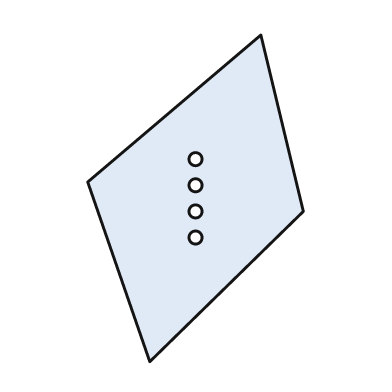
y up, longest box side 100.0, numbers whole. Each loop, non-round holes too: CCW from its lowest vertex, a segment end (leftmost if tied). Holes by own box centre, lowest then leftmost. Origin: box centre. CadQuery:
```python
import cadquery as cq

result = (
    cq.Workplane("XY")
    .moveTo(-14.0, -50.0)
    .lineTo(33.0, -4.0)
    .lineTo(20.0, 50.0)
    .lineTo(-33.0, 5.0)
    .close()
    .moveTo(0.0, -12.0)
    .circle(2.0)
    .moveTo(0.0, -4.0)
    .circle(2.0)
    .moveTo(0.0, 4.0)
    .circle(2.0)
    .moveTo(0.0, 12.0)
    .circle(2.0)
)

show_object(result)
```